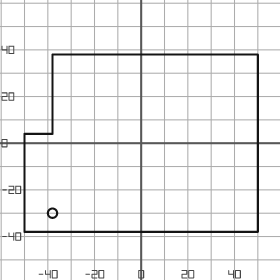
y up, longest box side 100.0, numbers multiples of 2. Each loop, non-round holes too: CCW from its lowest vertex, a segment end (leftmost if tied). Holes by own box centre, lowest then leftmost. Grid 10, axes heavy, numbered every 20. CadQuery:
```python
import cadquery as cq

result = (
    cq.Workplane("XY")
    .moveTo(-50.0, -38.0)
    .lineTo(50.0, -38.0)
    .lineTo(50.0, 38.0)
    .lineTo(-38.0, 38.0)
    .lineTo(-38.0, 4.0)
    .lineTo(-50.0, 4.0)
    .close()
    .moveTo(-38.0, -30.0)
    .circle(2.0)
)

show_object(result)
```